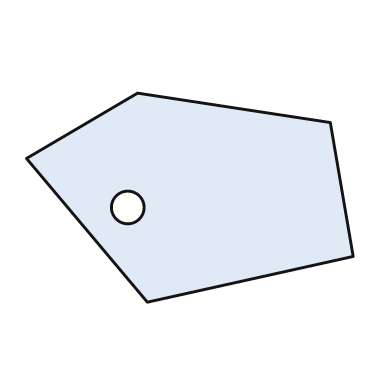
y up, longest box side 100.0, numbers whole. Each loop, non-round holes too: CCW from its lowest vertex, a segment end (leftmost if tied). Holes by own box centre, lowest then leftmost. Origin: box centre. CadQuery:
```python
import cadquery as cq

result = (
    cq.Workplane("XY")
    .moveTo(-13.0, -32.0)
    .lineTo(50.0, -18.0)
    .lineTo(43.0, 23.0)
    .lineTo(-16.0, 32.0)
    .lineTo(-50.0, 12.0)
    .close()
    .moveTo(-19.0, -3.0)
    .circle(5.0)
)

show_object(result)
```